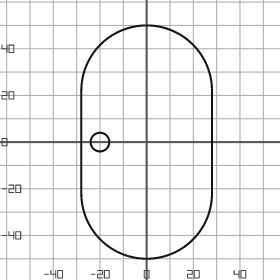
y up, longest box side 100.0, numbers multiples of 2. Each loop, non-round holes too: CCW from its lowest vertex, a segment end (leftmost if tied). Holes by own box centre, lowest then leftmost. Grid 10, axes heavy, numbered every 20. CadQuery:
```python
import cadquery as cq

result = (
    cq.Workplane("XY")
    .moveTo(-28.0, -22.0)
    .threePointArc((0.0, -50.0), (28.0, -22.0))
    .lineTo(28.0, 22.0)
    .threePointArc((0.0, 50.0), (-28.0, 22.0))
    .close()
    .moveTo(-20.0, 0.0)
    .circle(4.0)
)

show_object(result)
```